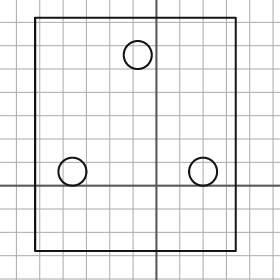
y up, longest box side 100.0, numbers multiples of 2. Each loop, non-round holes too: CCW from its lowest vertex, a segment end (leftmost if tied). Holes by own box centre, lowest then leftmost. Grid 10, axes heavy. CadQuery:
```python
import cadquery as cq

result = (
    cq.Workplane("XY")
    .moveTo(-52.0, -28.0)
    .lineTo(34.0, -28.0)
    .lineTo(34.0, 72.0)
    .lineTo(-52.0, 72.0)
    .close()
    .moveTo(-36.0, 6.0)
    .circle(6.0)
    .moveTo(20.0, 6.0)
    .circle(6.0)
    .moveTo(-8.0, 56.0)
    .circle(6.0)
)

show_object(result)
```